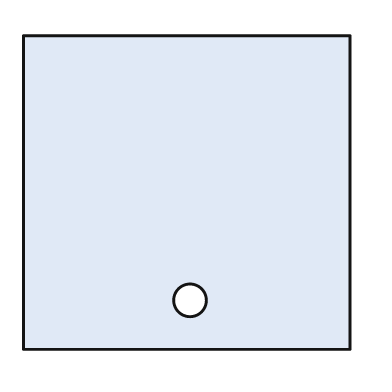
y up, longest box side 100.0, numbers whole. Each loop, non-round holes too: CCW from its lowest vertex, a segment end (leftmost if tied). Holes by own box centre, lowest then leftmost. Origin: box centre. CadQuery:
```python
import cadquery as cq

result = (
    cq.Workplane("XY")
    .moveTo(-50.0, -48.0)
    .lineTo(50.0, -48.0)
    .lineTo(50.0, 48.0)
    .lineTo(-50.0, 48.0)
    .close()
    .moveTo(1.0, -33.0)
    .circle(5.0)
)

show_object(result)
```